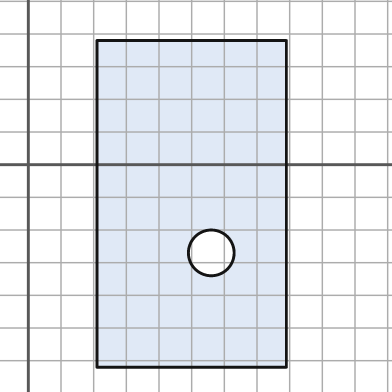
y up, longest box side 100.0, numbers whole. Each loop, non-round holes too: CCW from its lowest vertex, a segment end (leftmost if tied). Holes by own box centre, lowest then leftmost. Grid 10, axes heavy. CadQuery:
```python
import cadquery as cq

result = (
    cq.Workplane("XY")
    .moveTo(21.0, -62.0)
    .lineTo(79.0, -62.0)
    .lineTo(79.0, 38.0)
    .lineTo(21.0, 38.0)
    .close()
    .moveTo(56.0, -27.0)
    .circle(7.0)
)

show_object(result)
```